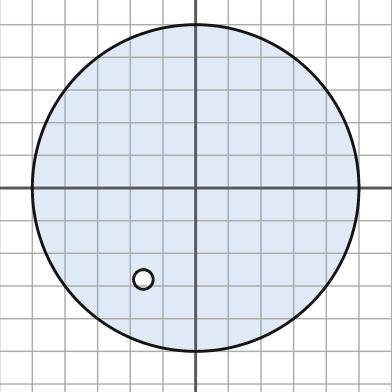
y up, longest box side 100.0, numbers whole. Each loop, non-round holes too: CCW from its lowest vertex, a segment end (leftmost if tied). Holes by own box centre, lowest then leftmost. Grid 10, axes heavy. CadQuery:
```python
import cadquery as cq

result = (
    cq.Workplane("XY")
    .moveTo(0.0, 0.0)
    .circle(50.0)
    .moveTo(-16.0, -28.0)
    .circle(3.0)
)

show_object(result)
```